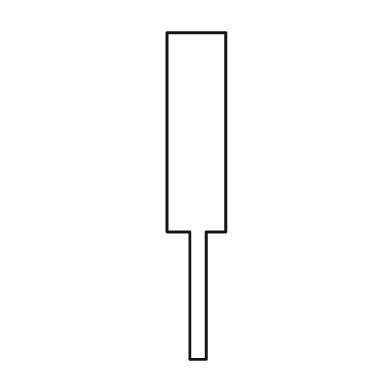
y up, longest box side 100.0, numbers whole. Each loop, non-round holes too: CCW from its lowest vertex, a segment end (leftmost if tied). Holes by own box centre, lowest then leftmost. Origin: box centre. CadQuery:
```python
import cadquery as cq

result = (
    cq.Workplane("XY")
    .moveTo(-2.0, -50.0)
    .lineTo(3.0, -50.0)
    .lineTo(3.0, -11.0)
    .lineTo(9.0, -11.0)
    .lineTo(9.0, 50.0)
    .lineTo(-9.0, 50.0)
    .lineTo(-9.0, -11.0)
    .lineTo(-2.0, -11.0)
    .close()
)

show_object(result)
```